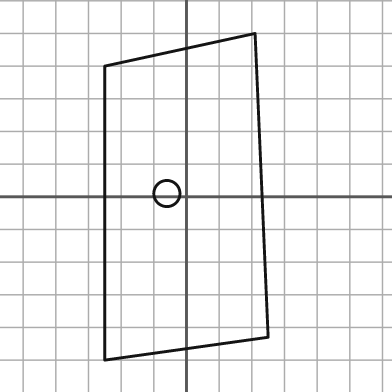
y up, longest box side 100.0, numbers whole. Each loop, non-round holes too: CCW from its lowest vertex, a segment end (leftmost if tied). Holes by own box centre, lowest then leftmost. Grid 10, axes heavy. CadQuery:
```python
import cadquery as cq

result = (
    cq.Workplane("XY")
    .moveTo(-25.0, -50.0)
    .lineTo(25.0, -43.0)
    .lineTo(21.0, 50.0)
    .lineTo(-25.0, 40.0)
    .close()
    .moveTo(-6.0, 1.0)
    .circle(4.0)
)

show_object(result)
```